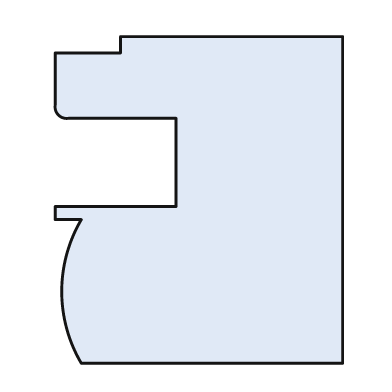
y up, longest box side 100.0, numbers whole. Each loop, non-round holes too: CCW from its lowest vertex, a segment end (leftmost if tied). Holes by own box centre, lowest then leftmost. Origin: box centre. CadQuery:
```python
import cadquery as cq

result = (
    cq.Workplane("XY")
    .moveTo(-36.0, -50.0)
    .lineTo(44.0, -50.0)
    .lineTo(44.0, 50.0)
    .lineTo(-24.0, 50.0)
    .lineTo(-24.0, 45.0)
    .lineTo(-44.0, 45.0)
    .lineTo(-44.0, 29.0)
    .threePointArc((-43.0, 26.0), (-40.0, 25.0))
    .lineTo(-7.0, 25.0)
    .lineTo(-7.0, -2.0)
    .lineTo(-44.0, -2.0)
    .lineTo(-44.0, -6.0)
    .lineTo(-36.0, -6.0)
    .threePointArc((-42.0, -28.0), (-36.0, -50.0))
    .close()
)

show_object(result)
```